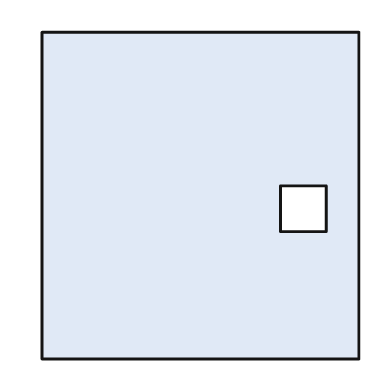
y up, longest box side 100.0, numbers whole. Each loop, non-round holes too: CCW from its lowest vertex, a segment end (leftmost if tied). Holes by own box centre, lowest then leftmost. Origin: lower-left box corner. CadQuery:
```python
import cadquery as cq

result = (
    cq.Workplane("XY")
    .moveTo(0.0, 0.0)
    .lineTo(97.0, 0.0)
    .lineTo(97.0, 100.0)
    .lineTo(0.0, 100.0)
    .close()
    .moveTo(73.0, 39.0)
    .lineTo(87.0, 39.0)
    .lineTo(87.0, 53.0)
    .lineTo(73.0, 53.0)
    .close()
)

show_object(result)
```